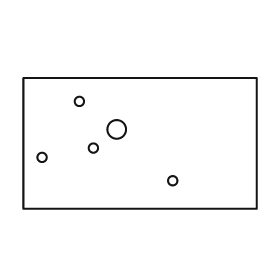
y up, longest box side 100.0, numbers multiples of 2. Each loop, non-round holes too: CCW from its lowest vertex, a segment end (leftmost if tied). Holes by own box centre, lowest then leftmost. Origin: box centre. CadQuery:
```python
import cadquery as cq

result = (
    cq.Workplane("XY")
    .moveTo(-50.0, -28.0)
    .lineTo(50.0, -28.0)
    .lineTo(50.0, 28.0)
    .lineTo(-50.0, 28.0)
    .close()
    .moveTo(14.0, -16.0)
    .circle(2.0)
    .moveTo(-42.0, -6.0)
    .circle(2.0)
    .moveTo(-20.0, -2.0)
    .circle(2.0)
    .moveTo(-10.0, 6.0)
    .circle(4.0)
    .moveTo(-26.0, 18.0)
    .circle(2.0)
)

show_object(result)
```